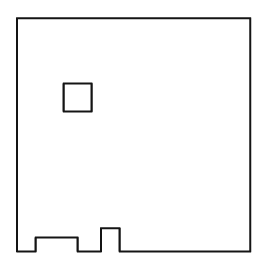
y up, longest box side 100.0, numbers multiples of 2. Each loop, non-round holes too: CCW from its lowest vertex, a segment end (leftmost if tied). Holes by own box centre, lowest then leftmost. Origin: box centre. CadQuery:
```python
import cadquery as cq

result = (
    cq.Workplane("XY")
    .moveTo(-50.0, -50.0)
    .lineTo(-42.0, -50.0)
    .lineTo(-42.0, -44.0)
    .lineTo(-24.0, -44.0)
    .lineTo(-24.0, -50.0)
    .lineTo(-14.0, -50.0)
    .lineTo(-14.0, -40.0)
    .lineTo(-6.0, -40.0)
    .lineTo(-6.0, -50.0)
    .lineTo(50.0, -50.0)
    .lineTo(50.0, 50.0)
    .lineTo(-50.0, 50.0)
    .close()
    .moveTo(-30.0, 10.0)
    .lineTo(-18.0, 10.0)
    .lineTo(-18.0, 22.0)
    .lineTo(-30.0, 22.0)
    .close()
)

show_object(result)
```